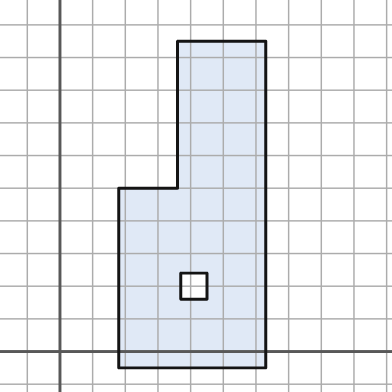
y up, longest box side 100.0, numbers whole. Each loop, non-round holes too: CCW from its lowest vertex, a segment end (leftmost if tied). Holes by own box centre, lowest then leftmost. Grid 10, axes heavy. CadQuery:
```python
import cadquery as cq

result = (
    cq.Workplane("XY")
    .moveTo(18.0, -5.0)
    .lineTo(63.0, -5.0)
    .lineTo(63.0, 95.0)
    .lineTo(36.0, 95.0)
    .lineTo(36.0, 50.0)
    .lineTo(18.0, 50.0)
    .close()
    .moveTo(37.0, 16.0)
    .lineTo(45.0, 16.0)
    .lineTo(45.0, 24.0)
    .lineTo(37.0, 24.0)
    .close()
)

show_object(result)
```